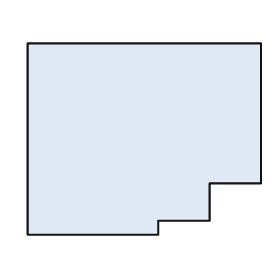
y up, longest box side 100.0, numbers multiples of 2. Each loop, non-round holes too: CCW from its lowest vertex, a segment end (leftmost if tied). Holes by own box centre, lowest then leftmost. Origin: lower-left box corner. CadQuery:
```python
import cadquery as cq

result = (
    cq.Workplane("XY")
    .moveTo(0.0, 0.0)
    .lineTo(56.0, 0.0)
    .lineTo(56.0, 6.0)
    .lineTo(78.0, 6.0)
    .lineTo(78.0, 22.0)
    .lineTo(100.0, 22.0)
    .lineTo(100.0, 82.0)
    .lineTo(0.0, 82.0)
    .close()
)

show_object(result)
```